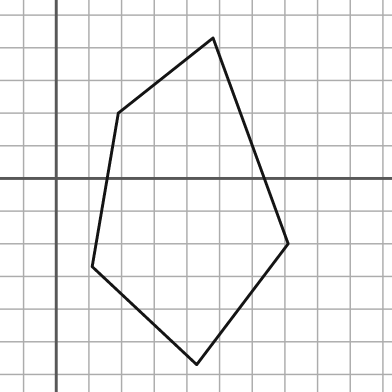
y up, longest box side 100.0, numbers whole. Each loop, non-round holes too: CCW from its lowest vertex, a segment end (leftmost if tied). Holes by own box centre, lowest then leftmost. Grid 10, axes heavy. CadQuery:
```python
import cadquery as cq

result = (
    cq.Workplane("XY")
    .moveTo(43.0, -57.0)
    .lineTo(71.0, -20.0)
    .lineTo(48.0, 43.0)
    .lineTo(19.0, 20.0)
    .lineTo(11.0, -27.0)
    .close()
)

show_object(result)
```